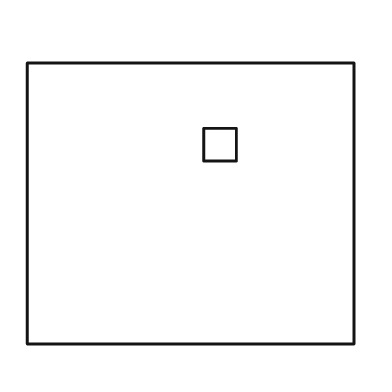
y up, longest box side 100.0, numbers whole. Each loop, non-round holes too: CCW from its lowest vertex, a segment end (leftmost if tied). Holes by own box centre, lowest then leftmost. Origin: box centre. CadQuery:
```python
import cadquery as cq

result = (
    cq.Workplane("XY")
    .moveTo(-50.0, -43.0)
    .lineTo(50.0, -43.0)
    .lineTo(50.0, 43.0)
    .lineTo(-50.0, 43.0)
    .close()
    .moveTo(4.0, 13.0)
    .lineTo(14.0, 13.0)
    .lineTo(14.0, 23.0)
    .lineTo(4.0, 23.0)
    .close()
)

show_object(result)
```